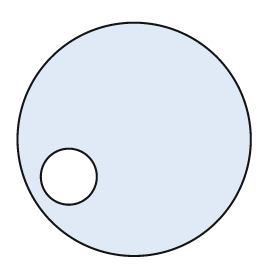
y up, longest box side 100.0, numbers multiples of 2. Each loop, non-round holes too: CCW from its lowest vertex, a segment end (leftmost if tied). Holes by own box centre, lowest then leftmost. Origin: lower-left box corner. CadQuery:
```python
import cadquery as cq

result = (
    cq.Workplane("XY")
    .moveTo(50.0, 50.0)
    .circle(50.0)
    .moveTo(22.0, 34.0)
    .circle(12.0)
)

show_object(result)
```